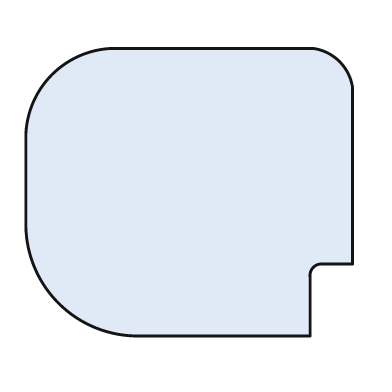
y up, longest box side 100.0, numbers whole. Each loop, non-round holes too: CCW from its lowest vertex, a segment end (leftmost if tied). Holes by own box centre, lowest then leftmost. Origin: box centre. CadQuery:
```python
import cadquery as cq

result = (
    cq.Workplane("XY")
    .moveTo(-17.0, -44.0)
    .lineTo(37.0, -44.0)
    .lineTo(37.0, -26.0)
    .threePointArc((38.0, -23.0), (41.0, -22.0))
    .lineTo(50.0, -22.0)
    .lineTo(50.0, 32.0)
    .threePointArc((46.0, 40.0), (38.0, 44.0))
    .lineTo(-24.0, 44.0)
    .threePointArc((-42.0, 36.0), (-50.0, 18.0))
    .lineTo(-50.0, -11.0)
    .threePointArc((-40.0, -34.0), (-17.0, -44.0))
    .close()
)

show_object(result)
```